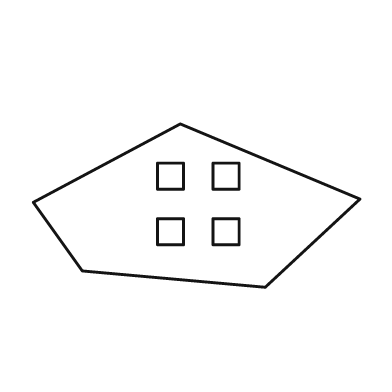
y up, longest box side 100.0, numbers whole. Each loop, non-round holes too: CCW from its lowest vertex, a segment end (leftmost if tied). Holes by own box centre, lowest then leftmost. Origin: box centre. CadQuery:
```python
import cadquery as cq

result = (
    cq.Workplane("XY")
    .moveTo(21.0, -25.0)
    .lineTo(50.0, 2.0)
    .lineTo(-5.0, 25.0)
    .lineTo(-50.0, 1.0)
    .lineTo(-35.0, -20.0)
    .close()
    .moveTo(-12.0, -12.0)
    .lineTo(-4.0, -12.0)
    .lineTo(-4.0, -4.0)
    .lineTo(-12.0, -4.0)
    .close()
    .moveTo(5.0, -12.0)
    .lineTo(13.0, -12.0)
    .lineTo(13.0, -4.0)
    .lineTo(5.0, -4.0)
    .close()
    .moveTo(-12.0, 5.0)
    .lineTo(-4.0, 5.0)
    .lineTo(-4.0, 13.0)
    .lineTo(-12.0, 13.0)
    .close()
    .moveTo(5.0, 5.0)
    .lineTo(13.0, 5.0)
    .lineTo(13.0, 13.0)
    .lineTo(5.0, 13.0)
    .close()
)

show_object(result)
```